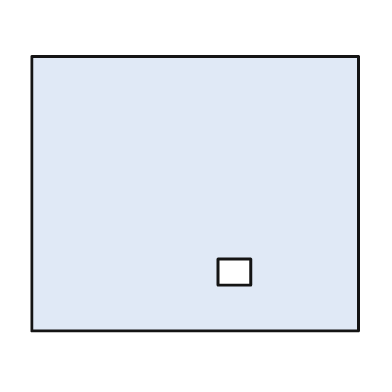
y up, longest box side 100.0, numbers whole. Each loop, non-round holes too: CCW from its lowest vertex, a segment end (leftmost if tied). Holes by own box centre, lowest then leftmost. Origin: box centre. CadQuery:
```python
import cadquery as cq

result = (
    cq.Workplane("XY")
    .moveTo(-50.0, -42.0)
    .lineTo(50.0, -42.0)
    .lineTo(50.0, 42.0)
    .lineTo(-50.0, 42.0)
    .close()
    .moveTo(7.0, -28.0)
    .lineTo(17.0, -28.0)
    .lineTo(17.0, -20.0)
    .lineTo(7.0, -20.0)
    .close()
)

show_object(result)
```